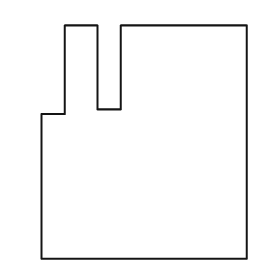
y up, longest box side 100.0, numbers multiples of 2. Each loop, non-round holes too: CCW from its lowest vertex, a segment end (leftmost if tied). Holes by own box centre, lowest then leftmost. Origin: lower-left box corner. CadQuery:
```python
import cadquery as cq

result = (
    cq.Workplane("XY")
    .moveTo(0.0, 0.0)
    .lineTo(88.0, 0.0)
    .lineTo(88.0, 100.0)
    .lineTo(34.0, 100.0)
    .lineTo(34.0, 64.0)
    .lineTo(24.0, 64.0)
    .lineTo(24.0, 100.0)
    .lineTo(10.0, 100.0)
    .lineTo(10.0, 62.0)
    .lineTo(0.0, 62.0)
    .close()
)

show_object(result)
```